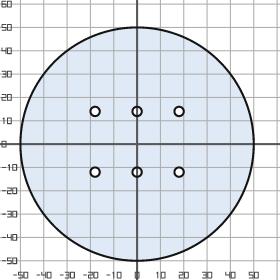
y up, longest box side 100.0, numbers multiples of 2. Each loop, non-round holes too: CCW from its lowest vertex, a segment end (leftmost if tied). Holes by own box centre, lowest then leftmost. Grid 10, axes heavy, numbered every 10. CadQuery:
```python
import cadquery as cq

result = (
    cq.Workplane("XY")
    .moveTo(0.0, 0.0)
    .circle(50.0)
    .moveTo(-18.0, -12.0)
    .circle(2.0)
    .moveTo(0.0, -12.0)
    .circle(2.0)
    .moveTo(18.0, -12.0)
    .circle(2.0)
    .moveTo(-18.0, 14.0)
    .circle(2.0)
    .moveTo(0.0, 14.0)
    .circle(2.0)
    .moveTo(18.0, 14.0)
    .circle(2.0)
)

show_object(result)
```